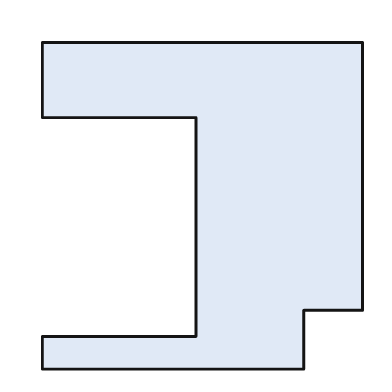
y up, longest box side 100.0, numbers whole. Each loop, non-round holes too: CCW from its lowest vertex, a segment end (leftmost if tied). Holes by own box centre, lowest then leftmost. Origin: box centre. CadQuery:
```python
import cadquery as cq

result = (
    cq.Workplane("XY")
    .moveTo(-49.0, -50.0)
    .lineTo(31.0, -50.0)
    .lineTo(31.0, -32.0)
    .lineTo(49.0, -32.0)
    .lineTo(49.0, 50.0)
    .lineTo(-49.0, 50.0)
    .lineTo(-49.0, 27.0)
    .lineTo(-2.0, 27.0)
    .lineTo(-2.0, -40.0)
    .lineTo(-49.0, -40.0)
    .close()
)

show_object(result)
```